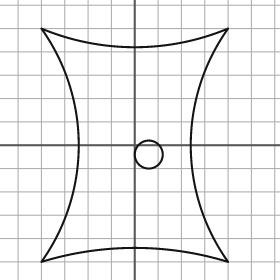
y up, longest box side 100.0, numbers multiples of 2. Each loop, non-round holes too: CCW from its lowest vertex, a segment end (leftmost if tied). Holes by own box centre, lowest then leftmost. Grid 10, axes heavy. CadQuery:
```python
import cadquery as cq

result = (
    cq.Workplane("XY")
    .moveTo(-40.0, -50.0)
    .threePointArc((0.0, -44.0), (40.0, -50.0))
    .threePointArc((24.0, 0.0), (40.0, 50.0))
    .threePointArc((0.0, 42.0), (-40.0, 50.0))
    .threePointArc((-24.0, 0.0), (-40.0, -50.0))
    .close()
    .moveTo(6.0, -4.0)
    .circle(6.0)
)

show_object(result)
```